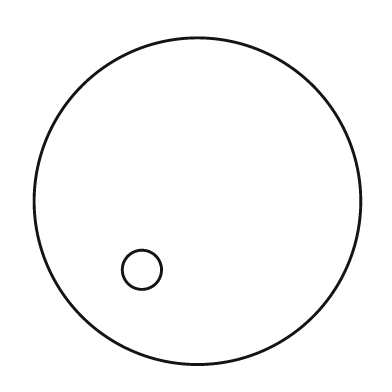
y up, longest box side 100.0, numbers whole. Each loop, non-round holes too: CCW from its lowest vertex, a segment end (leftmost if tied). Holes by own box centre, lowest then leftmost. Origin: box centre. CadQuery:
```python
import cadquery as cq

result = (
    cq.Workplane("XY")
    .moveTo(0.0, 0.0)
    .circle(50.0)
    .moveTo(-17.0, -21.0)
    .circle(6.0)
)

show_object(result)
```